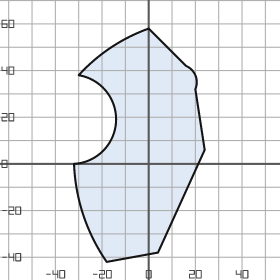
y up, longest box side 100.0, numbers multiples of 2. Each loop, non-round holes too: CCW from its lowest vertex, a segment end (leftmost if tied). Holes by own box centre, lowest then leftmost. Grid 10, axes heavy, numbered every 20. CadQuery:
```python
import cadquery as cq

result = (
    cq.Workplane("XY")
    .moveTo(-18.0, -42.0)
    .lineTo(4.0, -38.0)
    .lineTo(24.0, 6.0)
    .lineTo(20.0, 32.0)
    .threePointArc((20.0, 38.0), (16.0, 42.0))
    .lineTo(0.0, 58.0)
    .threePointArc((-16.0, 50.0), (-30.0, 38.0))
    .threePointArc((-14.0, 18.0), (-32.0, 0.0))
    .threePointArc((-28.0, -22.0), (-18.0, -42.0))
    .close()
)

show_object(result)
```